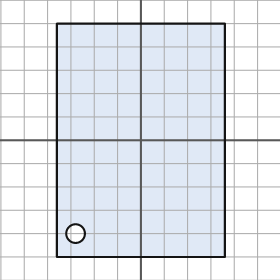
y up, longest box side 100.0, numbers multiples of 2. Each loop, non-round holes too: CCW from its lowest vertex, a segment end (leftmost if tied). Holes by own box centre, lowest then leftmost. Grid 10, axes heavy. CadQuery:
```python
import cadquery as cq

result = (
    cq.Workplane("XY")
    .moveTo(-36.0, -50.0)
    .lineTo(36.0, -50.0)
    .lineTo(36.0, 50.0)
    .lineTo(-36.0, 50.0)
    .close()
    .moveTo(-28.0, -40.0)
    .circle(4.0)
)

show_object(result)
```